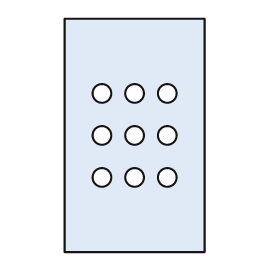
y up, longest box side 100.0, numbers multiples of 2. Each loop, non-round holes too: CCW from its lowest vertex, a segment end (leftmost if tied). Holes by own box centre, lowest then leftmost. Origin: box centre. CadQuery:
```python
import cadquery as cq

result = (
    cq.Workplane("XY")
    .moveTo(-30.0, -50.0)
    .lineTo(30.0, -50.0)
    .lineTo(30.0, 50.0)
    .lineTo(-30.0, 50.0)
    .close()
    .moveTo(-14.0, -18.0)
    .circle(4.0)
    .moveTo(0.0, -18.0)
    .circle(4.0)
    .moveTo(14.0, -18.0)
    .circle(4.0)
    .moveTo(-14.0, 0.0)
    .circle(4.0)
    .moveTo(0.0, 0.0)
    .circle(4.0)
    .moveTo(14.0, 0.0)
    .circle(4.0)
    .moveTo(-14.0, 18.0)
    .circle(4.0)
    .moveTo(0.0, 18.0)
    .circle(4.0)
    .moveTo(14.0, 18.0)
    .circle(4.0)
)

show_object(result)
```